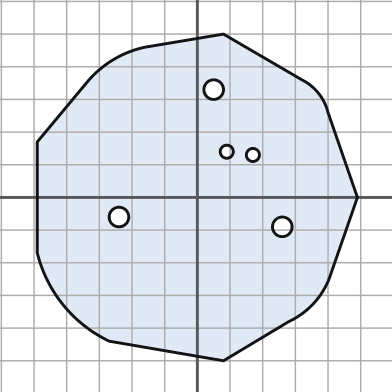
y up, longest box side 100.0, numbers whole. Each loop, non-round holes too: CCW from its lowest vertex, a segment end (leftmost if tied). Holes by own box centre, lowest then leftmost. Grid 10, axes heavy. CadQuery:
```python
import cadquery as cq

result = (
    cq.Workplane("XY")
    .moveTo(8.0, -50.0)
    .lineTo(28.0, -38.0)
    .threePointArc((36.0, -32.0), (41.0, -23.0))
    .lineTo(49.0, 0.0)
    .lineTo(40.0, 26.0)
    .threePointArc((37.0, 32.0), (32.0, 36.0))
    .lineTo(8.0, 50.0)
    .lineTo(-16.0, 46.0)
    .threePointArc((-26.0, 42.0), (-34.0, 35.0))
    .lineTo(-49.0, 17.0)
    .lineTo(-49.0, -17.0)
    .threePointArc((-41.0, -33.0), (-27.0, -44.0))
    .close()
    .moveTo(26.0, -9.0)
    .circle(3.0)
    .moveTo(-24.0, -6.0)
    .circle(3.0)
    .moveTo(17.0, 13.0)
    .circle(2.0)
    .moveTo(9.0, 14.0)
    .circle(2.0)
    .moveTo(5.0, 33.0)
    .circle(3.0)
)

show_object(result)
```